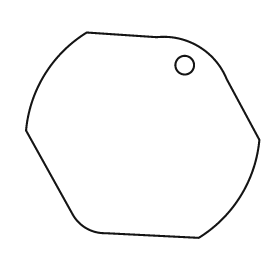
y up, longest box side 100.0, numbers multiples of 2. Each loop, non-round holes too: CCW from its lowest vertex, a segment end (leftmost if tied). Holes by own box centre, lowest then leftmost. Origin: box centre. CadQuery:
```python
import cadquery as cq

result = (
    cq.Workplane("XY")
    .moveTo(24.0, -44.0)
    .threePointArc((42.0, -26.0), (50.0, -2.0))
    .lineTo(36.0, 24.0)
    .threePointArc((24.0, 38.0), (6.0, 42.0))
    .lineTo(-24.0, 44.0)
    .threePointArc((-42.0, 26.0), (-50.0, 2.0))
    .lineTo(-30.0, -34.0)
    .threePointArc((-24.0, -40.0), (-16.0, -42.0))
    .close()
    .moveTo(18.0, 30.0)
    .circle(4.0)
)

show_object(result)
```